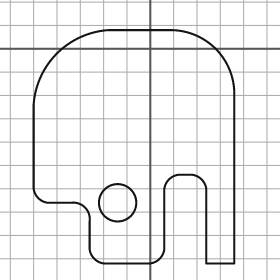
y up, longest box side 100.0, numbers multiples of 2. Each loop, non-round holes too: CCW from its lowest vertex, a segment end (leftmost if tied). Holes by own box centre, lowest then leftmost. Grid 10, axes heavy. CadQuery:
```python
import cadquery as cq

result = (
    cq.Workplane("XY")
    .moveTo(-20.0, -92.0)
    .lineTo(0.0, -92.0)
    .threePointArc((4.0, -90.0), (6.0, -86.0))
    .lineTo(6.0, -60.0)
    .threePointArc((8.0, -56.0), (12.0, -54.0))
    .lineTo(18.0, -54.0)
    .threePointArc((22.0, -56.0), (24.0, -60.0))
    .lineTo(24.0, -92.0)
    .lineTo(36.0, -92.0)
    .lineTo(36.0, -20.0)
    .threePointArc((28.0, 0.0), (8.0, 8.0))
    .lineTo(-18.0, 8.0)
    .threePointArc((-40.0, -2.0), (-50.0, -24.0))
    .lineTo(-50.0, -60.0)
    .threePointArc((-48.0, -64.0), (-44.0, -66.0))
    .lineTo(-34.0, -66.0)
    .threePointArc((-28.0, -68.0), (-26.0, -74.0))
    .lineTo(-26.0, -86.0)
    .threePointArc((-24.0, -90.0), (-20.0, -92.0))
    .close()
    .moveTo(-14.0, -66.0)
    .circle(8.0)
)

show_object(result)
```